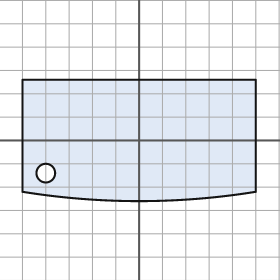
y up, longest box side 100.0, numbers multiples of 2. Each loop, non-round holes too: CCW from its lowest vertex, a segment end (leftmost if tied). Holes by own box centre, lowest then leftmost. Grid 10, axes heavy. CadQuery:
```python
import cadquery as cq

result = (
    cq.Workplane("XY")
    .moveTo(-50.0, -22.0)
    .threePointArc((0.0, -26.0), (50.0, -22.0))
    .lineTo(50.0, 26.0)
    .lineTo(-50.0, 26.0)
    .close()
    .moveTo(-40.0, -14.0)
    .circle(4.0)
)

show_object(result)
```